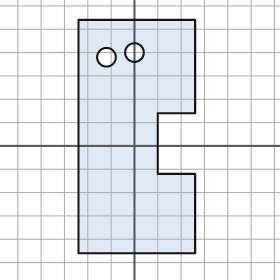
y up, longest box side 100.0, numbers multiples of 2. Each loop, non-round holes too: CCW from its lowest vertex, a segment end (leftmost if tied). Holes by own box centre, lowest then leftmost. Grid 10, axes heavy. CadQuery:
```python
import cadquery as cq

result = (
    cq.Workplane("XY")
    .moveTo(-24.0, -46.0)
    .lineTo(26.0, -46.0)
    .lineTo(26.0, -12.0)
    .lineTo(10.0, -12.0)
    .lineTo(10.0, 14.0)
    .lineTo(26.0, 14.0)
    .lineTo(26.0, 54.0)
    .lineTo(-24.0, 54.0)
    .close()
    .moveTo(-12.0, 38.0)
    .circle(4.0)
    .moveTo(0.0, 40.0)
    .circle(4.0)
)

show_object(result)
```